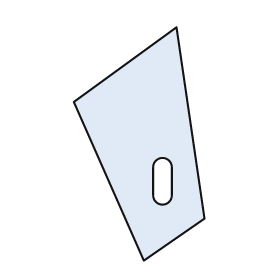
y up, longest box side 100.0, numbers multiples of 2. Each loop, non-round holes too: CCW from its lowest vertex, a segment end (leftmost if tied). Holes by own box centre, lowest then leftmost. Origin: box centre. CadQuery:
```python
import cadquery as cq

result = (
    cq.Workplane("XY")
    .moveTo(2.0, -50.0)
    .lineTo(28.0, -32.0)
    .lineTo(16.0, 50.0)
    .lineTo(-28.0, 18.0)
    .close()
    .moveTo(6.0, -22.0)
    .threePointArc((10.0, -26.0), (14.0, -22.0))
    .lineTo(14.0, -10.0)
    .threePointArc((10.0, -6.0), (6.0, -10.0))
    .close()
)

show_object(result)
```